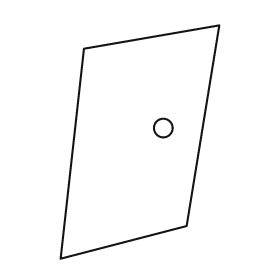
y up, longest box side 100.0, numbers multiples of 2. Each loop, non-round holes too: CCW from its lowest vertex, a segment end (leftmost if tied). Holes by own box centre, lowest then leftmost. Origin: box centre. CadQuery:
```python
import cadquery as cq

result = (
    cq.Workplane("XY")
    .moveTo(-34.0, -50.0)
    .lineTo(20.0, -36.0)
    .lineTo(34.0, 50.0)
    .lineTo(-24.0, 40.0)
    .close()
    .moveTo(10.0, 6.0)
    .circle(4.0)
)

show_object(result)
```